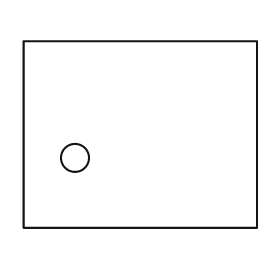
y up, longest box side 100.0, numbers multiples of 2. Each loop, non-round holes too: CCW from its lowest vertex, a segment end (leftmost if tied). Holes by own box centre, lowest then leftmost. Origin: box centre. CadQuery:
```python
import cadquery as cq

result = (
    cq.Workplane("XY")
    .moveTo(-50.0, -40.0)
    .lineTo(50.0, -40.0)
    .lineTo(50.0, 40.0)
    .lineTo(-50.0, 40.0)
    .close()
    .moveTo(-28.0, -10.0)
    .circle(6.0)
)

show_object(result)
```